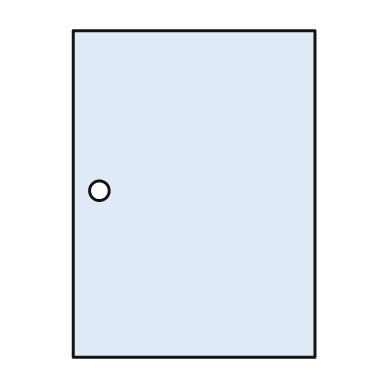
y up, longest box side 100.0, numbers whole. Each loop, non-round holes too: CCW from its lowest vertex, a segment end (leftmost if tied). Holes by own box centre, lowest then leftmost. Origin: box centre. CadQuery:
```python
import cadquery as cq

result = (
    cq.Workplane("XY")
    .moveTo(-37.0, -50.0)
    .lineTo(37.0, -50.0)
    .lineTo(37.0, 50.0)
    .lineTo(-37.0, 50.0)
    .close()
    .moveTo(-29.0, 1.0)
    .circle(3.0)
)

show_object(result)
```